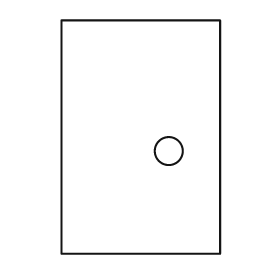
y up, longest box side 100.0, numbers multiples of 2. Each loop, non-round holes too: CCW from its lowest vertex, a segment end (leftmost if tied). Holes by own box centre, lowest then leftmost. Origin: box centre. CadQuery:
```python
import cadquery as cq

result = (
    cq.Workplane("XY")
    .moveTo(-34.0, -50.0)
    .lineTo(34.0, -50.0)
    .lineTo(34.0, 50.0)
    .lineTo(-34.0, 50.0)
    .close()
    .moveTo(12.0, -6.0)
    .circle(6.0)
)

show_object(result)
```